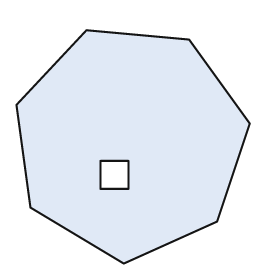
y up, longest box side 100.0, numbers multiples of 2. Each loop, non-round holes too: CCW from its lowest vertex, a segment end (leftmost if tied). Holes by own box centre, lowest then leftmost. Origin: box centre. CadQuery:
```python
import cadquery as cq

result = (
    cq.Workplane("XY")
    .moveTo(-4.0, -50.0)
    .lineTo(36.0, -32.0)
    .lineTo(50.0, 10.0)
    .lineTo(24.0, 46.0)
    .lineTo(-20.0, 50.0)
    .lineTo(-50.0, 18.0)
    .lineTo(-44.0, -26.0)
    .close()
    .moveTo(-14.0, -18.0)
    .lineTo(-2.0, -18.0)
    .lineTo(-2.0, -6.0)
    .lineTo(-14.0, -6.0)
    .close()
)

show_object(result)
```